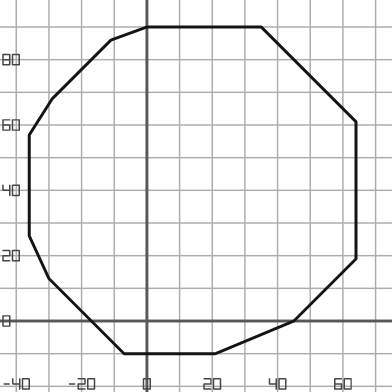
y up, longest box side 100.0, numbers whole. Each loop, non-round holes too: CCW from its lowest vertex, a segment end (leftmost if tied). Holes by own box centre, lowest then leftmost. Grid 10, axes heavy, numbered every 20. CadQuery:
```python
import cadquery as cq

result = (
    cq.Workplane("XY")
    .moveTo(-7.0, -10.0)
    .lineTo(21.0, -10.0)
    .lineTo(45.0, 0.0)
    .lineTo(64.0, 19.0)
    .lineTo(64.0, 61.0)
    .lineTo(35.0, 90.0)
    .lineTo(0.0, 90.0)
    .lineTo(-11.0, 86.0)
    .lineTo(-29.0, 68.0)
    .lineTo(-36.0, 57.0)
    .lineTo(-36.0, 26.0)
    .lineTo(-30.0, 13.0)
    .close()
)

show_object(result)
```